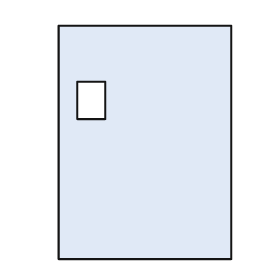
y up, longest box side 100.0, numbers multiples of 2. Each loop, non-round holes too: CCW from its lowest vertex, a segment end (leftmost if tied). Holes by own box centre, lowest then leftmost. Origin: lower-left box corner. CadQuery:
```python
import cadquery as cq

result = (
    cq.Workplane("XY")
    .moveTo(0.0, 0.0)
    .lineTo(74.0, 0.0)
    .lineTo(74.0, 100.0)
    .lineTo(0.0, 100.0)
    .close()
    .moveTo(8.0, 60.0)
    .lineTo(20.0, 60.0)
    .lineTo(20.0, 76.0)
    .lineTo(8.0, 76.0)
    .close()
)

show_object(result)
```